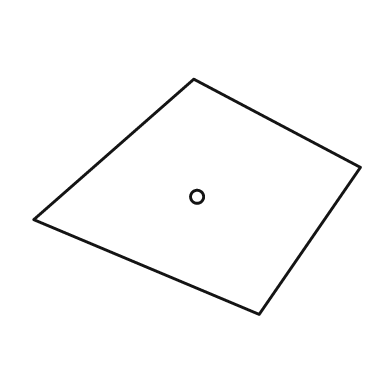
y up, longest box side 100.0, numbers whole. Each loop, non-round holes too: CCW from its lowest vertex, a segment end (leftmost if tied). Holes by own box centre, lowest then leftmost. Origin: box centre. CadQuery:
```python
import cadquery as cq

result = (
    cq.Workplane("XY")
    .moveTo(19.0, -36.0)
    .lineTo(50.0, 9.0)
    .lineTo(-1.0, 36.0)
    .lineTo(-50.0, -7.0)
    .close()
    .moveTo(0.0, 0.0)
    .circle(2.0)
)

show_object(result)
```